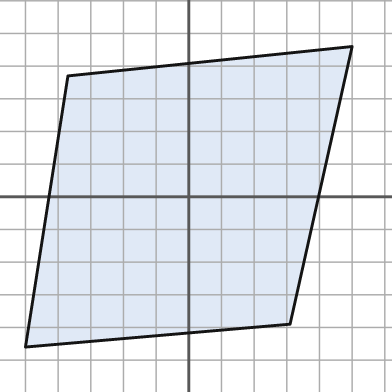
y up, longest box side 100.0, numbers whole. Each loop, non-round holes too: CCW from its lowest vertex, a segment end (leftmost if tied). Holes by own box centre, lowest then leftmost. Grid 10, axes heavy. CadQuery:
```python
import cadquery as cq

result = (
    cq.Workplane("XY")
    .moveTo(-50.0, -46.0)
    .lineTo(31.0, -39.0)
    .lineTo(50.0, 46.0)
    .lineTo(-37.0, 37.0)
    .close()
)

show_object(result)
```